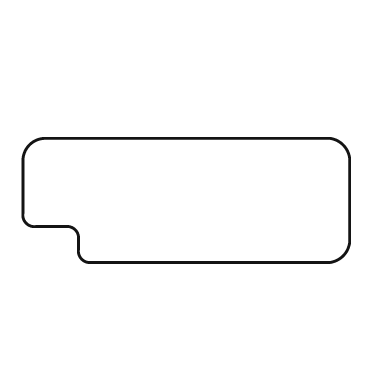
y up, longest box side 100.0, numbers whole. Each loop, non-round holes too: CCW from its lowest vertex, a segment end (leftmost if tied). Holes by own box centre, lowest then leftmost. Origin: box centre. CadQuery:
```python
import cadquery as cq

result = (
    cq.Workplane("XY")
    .moveTo(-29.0, -19.0)
    .lineTo(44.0, -19.0)
    .threePointArc((48.0, -17.0), (50.0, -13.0))
    .lineTo(50.0, 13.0)
    .threePointArc((48.0, 17.0), (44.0, 19.0))
    .lineTo(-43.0, 19.0)
    .threePointArc((-48.0, 17.0), (-50.0, 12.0))
    .lineTo(-50.0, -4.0)
    .threePointArc((-49.0, -7.0), (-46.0, -8.0))
    .lineTo(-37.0, -8.0)
    .threePointArc((-34.0, -9.0), (-33.0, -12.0))
    .lineTo(-33.0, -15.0)
    .threePointArc((-32.0, -18.0), (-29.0, -19.0))
    .close()
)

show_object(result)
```